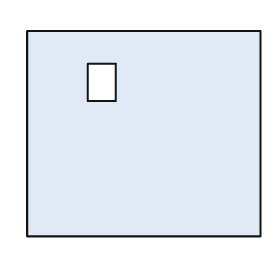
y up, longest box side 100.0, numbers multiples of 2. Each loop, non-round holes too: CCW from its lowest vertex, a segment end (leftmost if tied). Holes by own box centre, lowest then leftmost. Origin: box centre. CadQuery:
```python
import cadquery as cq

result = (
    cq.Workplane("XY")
    .moveTo(-50.0, -44.0)
    .lineTo(50.0, -44.0)
    .lineTo(50.0, 44.0)
    .lineTo(-50.0, 44.0)
    .close()
    .moveTo(-24.0, 14.0)
    .lineTo(-12.0, 14.0)
    .lineTo(-12.0, 30.0)
    .lineTo(-24.0, 30.0)
    .close()
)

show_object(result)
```